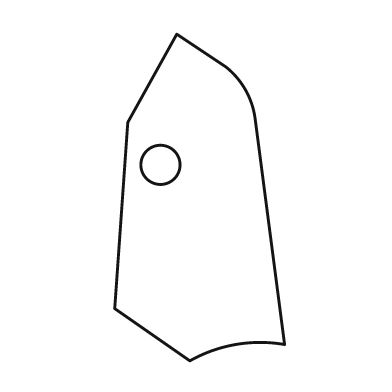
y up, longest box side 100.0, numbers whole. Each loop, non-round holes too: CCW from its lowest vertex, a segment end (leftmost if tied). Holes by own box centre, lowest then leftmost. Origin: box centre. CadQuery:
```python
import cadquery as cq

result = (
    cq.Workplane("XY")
    .moveTo(-3.0, -50.0)
    .threePointArc((11.0, -45.0), (26.0, -45.0))
    .lineTo(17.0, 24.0)
    .threePointArc((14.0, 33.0), (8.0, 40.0))
    .lineTo(-7.0, 50.0)
    .lineTo(-22.0, 23.0)
    .lineTo(-26.0, -34.0)
    .close()
    .moveTo(-12.0, 10.0)
    .circle(6.0)
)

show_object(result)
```